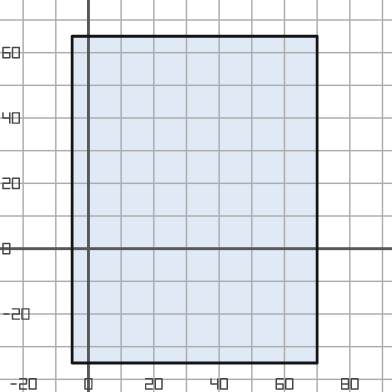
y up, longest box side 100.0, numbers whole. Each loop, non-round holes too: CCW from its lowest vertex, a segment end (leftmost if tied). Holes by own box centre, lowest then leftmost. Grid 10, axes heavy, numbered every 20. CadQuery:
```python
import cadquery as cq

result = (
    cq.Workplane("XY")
    .moveTo(-5.0, -35.0)
    .lineTo(70.0, -35.0)
    .lineTo(70.0, 65.0)
    .lineTo(-5.0, 65.0)
    .close()
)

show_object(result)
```